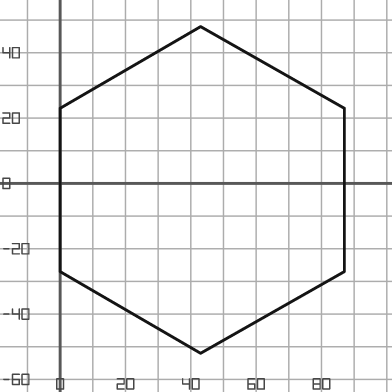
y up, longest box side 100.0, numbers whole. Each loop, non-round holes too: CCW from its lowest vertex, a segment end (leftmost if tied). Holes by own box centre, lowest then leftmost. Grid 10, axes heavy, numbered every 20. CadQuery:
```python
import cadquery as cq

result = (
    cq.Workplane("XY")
    .moveTo(43.0, -52.0)
    .lineTo(87.0, -27.0)
    .lineTo(87.0, 23.0)
    .lineTo(43.0, 48.0)
    .lineTo(0.0, 23.0)
    .lineTo(0.0, -27.0)
    .close()
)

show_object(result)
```